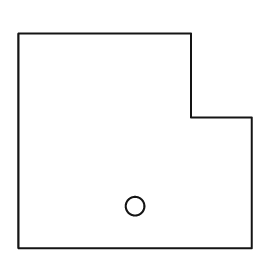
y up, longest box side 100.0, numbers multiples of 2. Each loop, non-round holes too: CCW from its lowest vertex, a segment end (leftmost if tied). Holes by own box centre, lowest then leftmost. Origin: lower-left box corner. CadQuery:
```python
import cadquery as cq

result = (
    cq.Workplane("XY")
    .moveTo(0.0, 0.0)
    .lineTo(100.0, 0.0)
    .lineTo(100.0, 56.0)
    .lineTo(74.0, 56.0)
    .lineTo(74.0, 92.0)
    .lineTo(0.0, 92.0)
    .close()
    .moveTo(50.0, 18.0)
    .circle(4.0)
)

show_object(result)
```